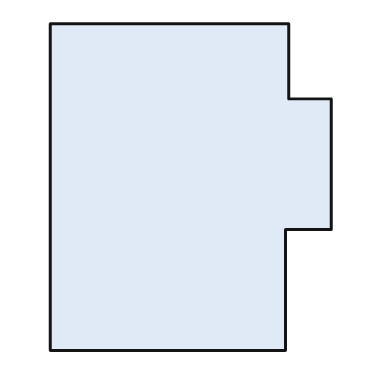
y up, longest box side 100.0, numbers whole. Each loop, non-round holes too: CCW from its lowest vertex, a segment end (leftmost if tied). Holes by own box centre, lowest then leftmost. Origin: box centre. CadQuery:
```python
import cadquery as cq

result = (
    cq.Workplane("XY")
    .moveTo(-43.0, -50.0)
    .lineTo(29.0, -50.0)
    .lineTo(29.0, -13.0)
    .lineTo(43.0, -13.0)
    .lineTo(43.0, 27.0)
    .lineTo(30.0, 27.0)
    .lineTo(30.0, 50.0)
    .lineTo(-43.0, 50.0)
    .close()
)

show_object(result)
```